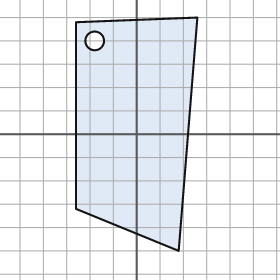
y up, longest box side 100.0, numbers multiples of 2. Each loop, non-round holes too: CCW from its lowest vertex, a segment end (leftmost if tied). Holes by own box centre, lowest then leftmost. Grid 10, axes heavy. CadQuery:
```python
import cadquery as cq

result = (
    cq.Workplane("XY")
    .moveTo(18.0, -50.0)
    .lineTo(26.0, 50.0)
    .lineTo(-26.0, 48.0)
    .lineTo(-26.0, -32.0)
    .close()
    .moveTo(-18.0, 40.0)
    .circle(4.0)
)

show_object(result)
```